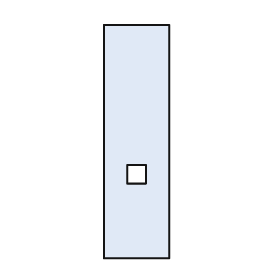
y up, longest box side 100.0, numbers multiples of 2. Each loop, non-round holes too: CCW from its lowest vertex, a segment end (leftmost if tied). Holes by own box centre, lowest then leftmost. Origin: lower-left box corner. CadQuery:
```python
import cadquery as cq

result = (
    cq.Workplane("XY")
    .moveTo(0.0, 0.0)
    .lineTo(28.0, 0.0)
    .lineTo(28.0, 100.0)
    .lineTo(0.0, 100.0)
    .close()
    .moveTo(10.0, 32.0)
    .lineTo(18.0, 32.0)
    .lineTo(18.0, 40.0)
    .lineTo(10.0, 40.0)
    .close()
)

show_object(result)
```